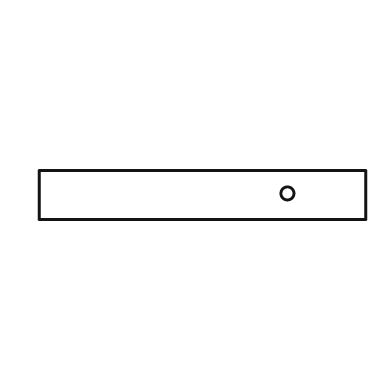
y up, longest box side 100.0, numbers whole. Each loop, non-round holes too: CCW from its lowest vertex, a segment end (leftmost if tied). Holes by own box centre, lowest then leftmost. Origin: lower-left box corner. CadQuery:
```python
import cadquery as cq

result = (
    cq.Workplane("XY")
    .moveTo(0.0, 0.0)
    .lineTo(100.0, 0.0)
    .lineTo(100.0, 15.0)
    .lineTo(0.0, 15.0)
    .close()
    .moveTo(76.0, 8.0)
    .circle(2.0)
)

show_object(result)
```